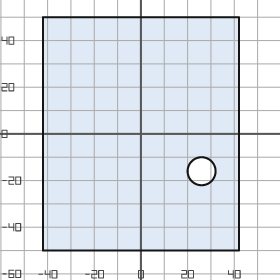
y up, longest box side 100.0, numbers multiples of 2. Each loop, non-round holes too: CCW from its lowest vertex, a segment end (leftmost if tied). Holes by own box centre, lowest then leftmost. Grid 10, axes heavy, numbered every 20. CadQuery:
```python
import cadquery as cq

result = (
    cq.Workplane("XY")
    .moveTo(-42.0, -50.0)
    .lineTo(42.0, -50.0)
    .lineTo(42.0, 50.0)
    .lineTo(-42.0, 50.0)
    .close()
    .moveTo(26.0, -16.0)
    .circle(6.0)
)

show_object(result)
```